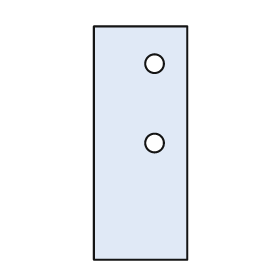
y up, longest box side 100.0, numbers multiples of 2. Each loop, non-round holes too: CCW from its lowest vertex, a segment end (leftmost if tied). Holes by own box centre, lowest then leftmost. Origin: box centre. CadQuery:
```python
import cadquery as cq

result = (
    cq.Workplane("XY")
    .moveTo(-20.0, -50.0)
    .lineTo(20.0, -50.0)
    .lineTo(20.0, 50.0)
    .lineTo(-20.0, 50.0)
    .close()
    .moveTo(6.0, 0.0)
    .circle(4.0)
    .moveTo(6.0, 34.0)
    .circle(4.0)
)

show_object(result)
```